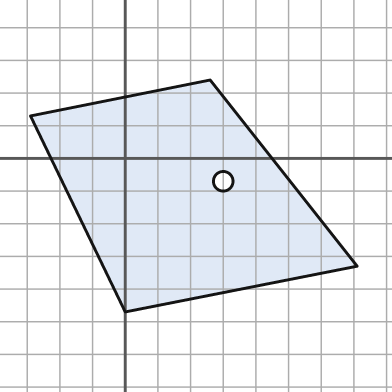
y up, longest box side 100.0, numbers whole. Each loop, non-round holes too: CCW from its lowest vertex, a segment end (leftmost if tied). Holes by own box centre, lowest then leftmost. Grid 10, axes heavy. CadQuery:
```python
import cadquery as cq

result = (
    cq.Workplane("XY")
    .moveTo(0.0, -47.0)
    .lineTo(71.0, -33.0)
    .lineTo(26.0, 24.0)
    .lineTo(-29.0, 13.0)
    .close()
    .moveTo(30.0, -7.0)
    .circle(3.0)
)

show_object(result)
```